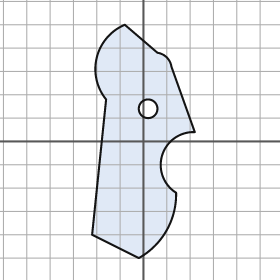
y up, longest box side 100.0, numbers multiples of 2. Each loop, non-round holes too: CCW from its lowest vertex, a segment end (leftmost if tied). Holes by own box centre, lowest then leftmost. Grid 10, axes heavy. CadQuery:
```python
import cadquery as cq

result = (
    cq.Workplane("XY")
    .moveTo(-2.0, -50.0)
    .threePointArc((10.0, -38.0), (14.0, -22.0))
    .threePointArc((8.0, -6.0), (22.0, 4.0))
    .lineTo(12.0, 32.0)
    .threePointArc((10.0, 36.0), (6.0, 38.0))
    .lineTo(-8.0, 50.0)
    .threePointArc((-20.0, 36.0), (-16.0, 18.0))
    .lineTo(-22.0, -40.0)
    .close()
    .moveTo(2.0, 14.0)
    .circle(4.0)
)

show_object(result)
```